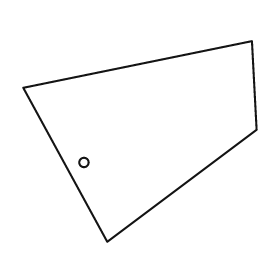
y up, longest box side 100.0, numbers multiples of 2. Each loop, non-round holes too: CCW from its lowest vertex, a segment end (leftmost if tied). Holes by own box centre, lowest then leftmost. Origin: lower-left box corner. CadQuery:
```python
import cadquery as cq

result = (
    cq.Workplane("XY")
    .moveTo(36.0, 0.0)
    .lineTo(100.0, 48.0)
    .lineTo(98.0, 86.0)
    .lineTo(0.0, 66.0)
    .close()
    .moveTo(26.0, 34.0)
    .circle(2.0)
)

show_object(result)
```